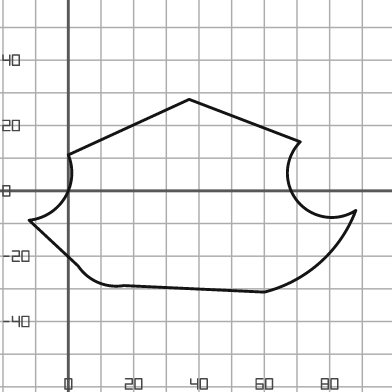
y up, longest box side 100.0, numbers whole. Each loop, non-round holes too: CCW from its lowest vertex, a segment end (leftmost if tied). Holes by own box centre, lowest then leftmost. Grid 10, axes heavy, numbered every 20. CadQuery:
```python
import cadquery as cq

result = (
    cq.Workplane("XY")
    .moveTo(60.0, -31.0)
    .threePointArc((77.0, -22.0), (88.0, -6.0))
    .threePointArc((70.0, -3.0), (71.0, 15.0))
    .lineTo(37.0, 28.0)
    .lineTo(0.0, 11.0)
    .threePointArc((-1.0, -2.0), (-12.0, -9.0))
    .lineTo(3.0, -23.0)
    .threePointArc((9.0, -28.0), (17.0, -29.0))
    .close()
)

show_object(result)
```